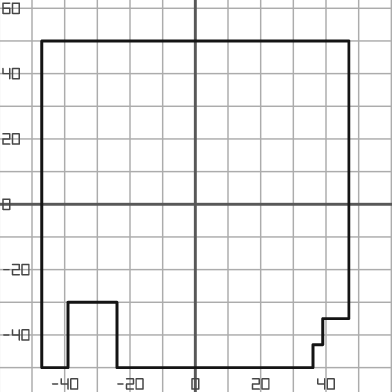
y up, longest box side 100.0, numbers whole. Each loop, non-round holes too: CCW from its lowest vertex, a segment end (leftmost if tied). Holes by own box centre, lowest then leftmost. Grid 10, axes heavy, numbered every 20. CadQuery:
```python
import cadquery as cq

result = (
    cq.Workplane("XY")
    .moveTo(-47.0, -50.0)
    .lineTo(-39.0, -50.0)
    .lineTo(-39.0, -30.0)
    .lineTo(-24.0, -30.0)
    .lineTo(-24.0, -50.0)
    .lineTo(36.0, -50.0)
    .lineTo(36.0, -43.0)
    .lineTo(39.0, -43.0)
    .lineTo(39.0, -35.0)
    .lineTo(47.0, -35.0)
    .lineTo(47.0, 50.0)
    .lineTo(-47.0, 50.0)
    .close()
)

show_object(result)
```